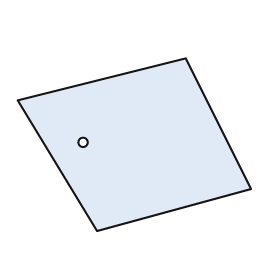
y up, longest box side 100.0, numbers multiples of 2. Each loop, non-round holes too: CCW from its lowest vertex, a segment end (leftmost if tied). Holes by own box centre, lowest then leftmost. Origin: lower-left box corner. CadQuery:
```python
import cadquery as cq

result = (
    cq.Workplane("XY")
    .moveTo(34.0, 0.0)
    .lineTo(100.0, 18.0)
    .lineTo(72.0, 74.0)
    .lineTo(0.0, 56.0)
    .close()
    .moveTo(28.0, 38.0)
    .circle(2.0)
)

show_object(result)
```